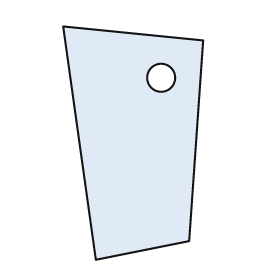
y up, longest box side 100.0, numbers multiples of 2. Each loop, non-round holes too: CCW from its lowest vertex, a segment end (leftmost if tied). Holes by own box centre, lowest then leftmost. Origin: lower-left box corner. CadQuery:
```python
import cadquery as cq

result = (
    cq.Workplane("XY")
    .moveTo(14.0, 0.0)
    .lineTo(54.0, 8.0)
    .lineTo(60.0, 94.0)
    .lineTo(0.0, 100.0)
    .close()
    .moveTo(42.0, 78.0)
    .circle(6.0)
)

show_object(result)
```